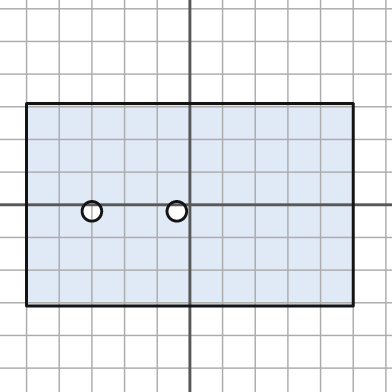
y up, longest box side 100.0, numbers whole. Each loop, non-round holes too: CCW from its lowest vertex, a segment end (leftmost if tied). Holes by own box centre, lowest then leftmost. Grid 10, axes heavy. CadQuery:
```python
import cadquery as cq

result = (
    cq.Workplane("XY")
    .moveTo(-50.0, -31.0)
    .lineTo(50.0, -31.0)
    .lineTo(50.0, 31.0)
    .lineTo(-50.0, 31.0)
    .close()
    .moveTo(-30.0, -2.0)
    .circle(3.0)
    .moveTo(-4.0, -2.0)
    .circle(3.0)
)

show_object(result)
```